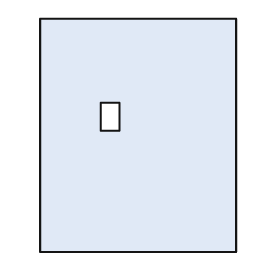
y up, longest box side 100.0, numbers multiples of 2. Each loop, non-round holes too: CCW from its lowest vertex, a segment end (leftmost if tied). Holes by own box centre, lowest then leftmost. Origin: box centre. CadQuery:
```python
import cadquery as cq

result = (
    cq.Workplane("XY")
    .moveTo(-42.0, -50.0)
    .lineTo(42.0, -50.0)
    .lineTo(42.0, 50.0)
    .lineTo(-42.0, 50.0)
    .close()
    .moveTo(-16.0, 2.0)
    .lineTo(-8.0, 2.0)
    .lineTo(-8.0, 14.0)
    .lineTo(-16.0, 14.0)
    .close()
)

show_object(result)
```